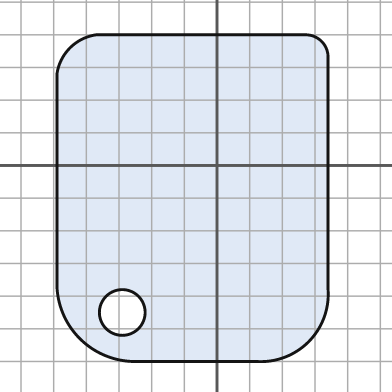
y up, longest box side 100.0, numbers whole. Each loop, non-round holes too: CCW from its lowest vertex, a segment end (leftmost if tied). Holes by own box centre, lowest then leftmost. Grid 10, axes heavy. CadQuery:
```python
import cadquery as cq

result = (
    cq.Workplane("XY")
    .moveTo(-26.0, -60.0)
    .lineTo(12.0, -60.0)
    .threePointArc((28.0, -54.0), (34.0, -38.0))
    .lineTo(34.0, 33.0)
    .threePointArc((32.0, 38.0), (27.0, 40.0))
    .lineTo(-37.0, 40.0)
    .threePointArc((-45.0, 36.0), (-49.0, 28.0))
    .lineTo(-49.0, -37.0)
    .threePointArc((-42.0, -53.0), (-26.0, -60.0))
    .close()
    .moveTo(-29.0, -45.0)
    .circle(7.0)
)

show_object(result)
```